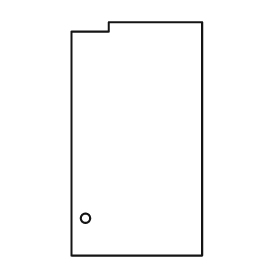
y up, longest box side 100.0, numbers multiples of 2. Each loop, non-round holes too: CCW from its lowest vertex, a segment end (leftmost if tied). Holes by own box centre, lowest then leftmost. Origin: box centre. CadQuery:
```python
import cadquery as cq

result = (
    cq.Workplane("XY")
    .moveTo(-28.0, -50.0)
    .lineTo(28.0, -50.0)
    .lineTo(28.0, 50.0)
    .lineTo(-12.0, 50.0)
    .lineTo(-12.0, 46.0)
    .lineTo(-28.0, 46.0)
    .close()
    .moveTo(-22.0, -34.0)
    .circle(2.0)
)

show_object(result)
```